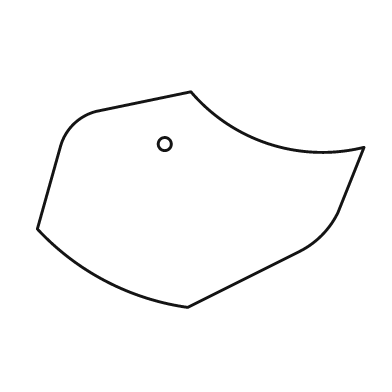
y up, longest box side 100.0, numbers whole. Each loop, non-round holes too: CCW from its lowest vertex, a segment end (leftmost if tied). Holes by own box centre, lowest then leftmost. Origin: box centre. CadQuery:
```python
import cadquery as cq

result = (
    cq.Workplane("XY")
    .moveTo(-4.0, -33.0)
    .lineTo(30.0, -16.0)
    .threePointArc((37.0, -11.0), (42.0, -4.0))
    .lineTo(50.0, 16.0)
    .threePointArc((21.0, 17.0), (-3.0, 33.0))
    .lineTo(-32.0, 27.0)
    .threePointArc((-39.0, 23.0), (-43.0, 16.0))
    .lineTo(-50.0, -9.0)
    .threePointArc((-29.0, -25.0), (-4.0, -33.0))
    .close()
    .moveTo(-11.0, 17.0)
    .circle(2.0)
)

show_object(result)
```